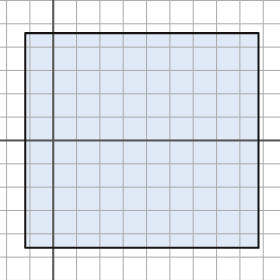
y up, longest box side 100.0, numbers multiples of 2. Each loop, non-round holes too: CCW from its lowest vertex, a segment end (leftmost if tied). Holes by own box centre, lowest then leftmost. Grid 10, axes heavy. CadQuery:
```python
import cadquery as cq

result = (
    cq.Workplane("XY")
    .moveTo(-12.0, -46.0)
    .lineTo(88.0, -46.0)
    .lineTo(88.0, 46.0)
    .lineTo(-12.0, 46.0)
    .close()
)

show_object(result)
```